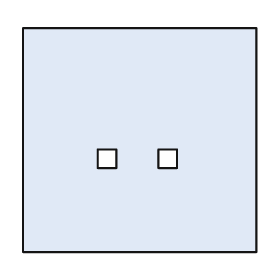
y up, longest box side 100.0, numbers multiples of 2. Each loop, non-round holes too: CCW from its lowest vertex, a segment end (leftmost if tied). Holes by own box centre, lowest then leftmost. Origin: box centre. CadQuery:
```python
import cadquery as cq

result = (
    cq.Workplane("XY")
    .moveTo(-50.0, -48.0)
    .lineTo(50.0, -48.0)
    .lineTo(50.0, 48.0)
    .lineTo(-50.0, 48.0)
    .close()
    .moveTo(-18.0, -12.0)
    .lineTo(-10.0, -12.0)
    .lineTo(-10.0, -4.0)
    .lineTo(-18.0, -4.0)
    .close()
    .moveTo(8.0, -12.0)
    .lineTo(16.0, -12.0)
    .lineTo(16.0, -4.0)
    .lineTo(8.0, -4.0)
    .close()
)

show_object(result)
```